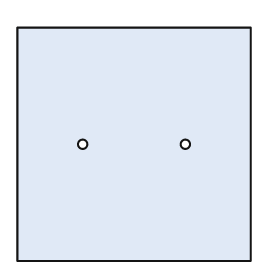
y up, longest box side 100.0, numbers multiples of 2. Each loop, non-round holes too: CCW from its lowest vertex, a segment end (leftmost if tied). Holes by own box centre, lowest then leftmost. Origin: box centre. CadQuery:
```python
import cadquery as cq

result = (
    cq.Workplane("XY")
    .moveTo(-50.0, -50.0)
    .lineTo(50.0, -50.0)
    .lineTo(50.0, 50.0)
    .lineTo(-50.0, 50.0)
    .close()
    .moveTo(-22.0, 0.0)
    .circle(2.0)
    .moveTo(22.0, 0.0)
    .circle(2.0)
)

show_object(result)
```